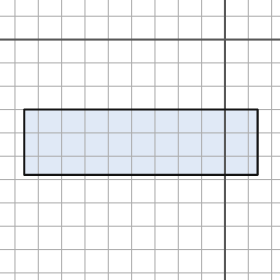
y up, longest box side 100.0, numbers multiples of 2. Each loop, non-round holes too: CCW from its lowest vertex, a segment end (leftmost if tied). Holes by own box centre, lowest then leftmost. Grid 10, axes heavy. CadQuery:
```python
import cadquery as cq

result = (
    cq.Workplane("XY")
    .moveTo(-86.0, -58.0)
    .lineTo(14.0, -58.0)
    .lineTo(14.0, -30.0)
    .lineTo(-86.0, -30.0)
    .close()
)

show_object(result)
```